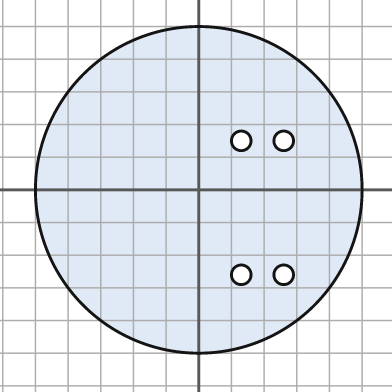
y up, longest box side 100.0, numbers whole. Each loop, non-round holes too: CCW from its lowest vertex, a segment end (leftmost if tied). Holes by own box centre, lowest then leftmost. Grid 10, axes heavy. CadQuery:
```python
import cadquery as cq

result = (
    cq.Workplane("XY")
    .moveTo(0.0, 0.0)
    .circle(50.0)
    .moveTo(13.0, -26.0)
    .circle(3.0)
    .moveTo(26.0, -26.0)
    .circle(3.0)
    .moveTo(13.0, 15.0)
    .circle(3.0)
    .moveTo(26.0, 15.0)
    .circle(3.0)
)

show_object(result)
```